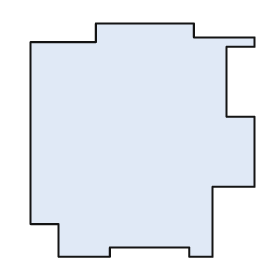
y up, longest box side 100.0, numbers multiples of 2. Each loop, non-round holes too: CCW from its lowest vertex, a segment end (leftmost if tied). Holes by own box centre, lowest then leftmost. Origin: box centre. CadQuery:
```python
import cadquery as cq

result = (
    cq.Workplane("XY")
    .moveTo(-36.0, -50.0)
    .lineTo(-14.0, -50.0)
    .lineTo(-14.0, -46.0)
    .lineTo(20.0, -46.0)
    .lineTo(20.0, -50.0)
    .lineTo(30.0, -50.0)
    .lineTo(30.0, -20.0)
    .lineTo(48.0, -20.0)
    .lineTo(48.0, 10.0)
    .lineTo(36.0, 10.0)
    .lineTo(36.0, 40.0)
    .lineTo(48.0, 40.0)
    .lineTo(48.0, 44.0)
    .lineTo(22.0, 44.0)
    .lineTo(22.0, 50.0)
    .lineTo(-20.0, 50.0)
    .lineTo(-20.0, 42.0)
    .lineTo(-48.0, 42.0)
    .lineTo(-48.0, -36.0)
    .lineTo(-36.0, -36.0)
    .close()
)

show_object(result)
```